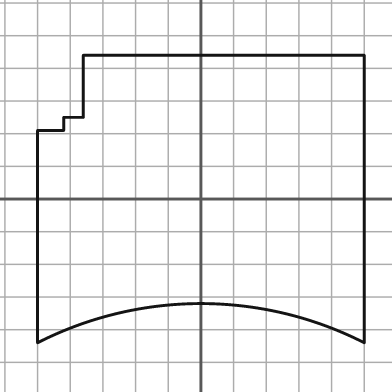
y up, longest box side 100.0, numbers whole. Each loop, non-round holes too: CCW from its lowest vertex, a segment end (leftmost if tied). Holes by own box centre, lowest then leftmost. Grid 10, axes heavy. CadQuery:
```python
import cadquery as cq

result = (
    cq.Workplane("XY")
    .moveTo(-50.0, -44.0)
    .threePointArc((0.0, -32.0), (50.0, -44.0))
    .lineTo(50.0, 44.0)
    .lineTo(-36.0, 44.0)
    .lineTo(-36.0, 25.0)
    .lineTo(-42.0, 25.0)
    .lineTo(-42.0, 21.0)
    .lineTo(-50.0, 21.0)
    .close()
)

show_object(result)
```